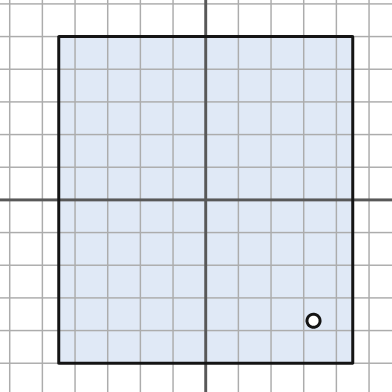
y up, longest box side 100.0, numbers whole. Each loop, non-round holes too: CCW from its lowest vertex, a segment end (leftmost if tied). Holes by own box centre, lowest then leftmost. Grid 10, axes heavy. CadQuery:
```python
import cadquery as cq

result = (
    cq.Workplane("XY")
    .moveTo(-45.0, -50.0)
    .lineTo(45.0, -50.0)
    .lineTo(45.0, 50.0)
    .lineTo(-45.0, 50.0)
    .close()
    .moveTo(33.0, -37.0)
    .circle(2.0)
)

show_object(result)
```